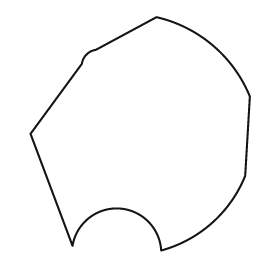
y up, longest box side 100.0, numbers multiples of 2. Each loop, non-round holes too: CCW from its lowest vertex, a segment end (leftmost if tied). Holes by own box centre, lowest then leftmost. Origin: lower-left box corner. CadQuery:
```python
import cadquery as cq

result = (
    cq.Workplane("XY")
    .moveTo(56.0, 0.0)
    .threePointArc((78.0, 12.0), (92.0, 32.0))
    .lineTo(94.0, 66.0)
    .threePointArc((78.0, 88.0), (54.0, 100.0))
    .lineTo(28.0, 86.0)
    .threePointArc((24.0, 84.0), (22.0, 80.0))
    .lineTo(0.0, 50.0)
    .lineTo(18.0, 2.0)
    .threePointArc((38.0, 18.0), (56.0, 0.0))
    .close()
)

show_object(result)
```